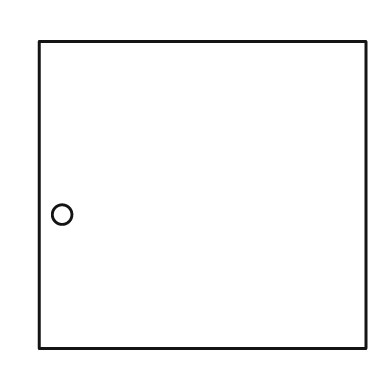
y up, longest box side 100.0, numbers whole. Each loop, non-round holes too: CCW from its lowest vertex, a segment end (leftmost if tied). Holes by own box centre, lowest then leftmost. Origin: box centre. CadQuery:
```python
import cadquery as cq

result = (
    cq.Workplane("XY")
    .moveTo(-50.0, -47.0)
    .lineTo(50.0, -47.0)
    .lineTo(50.0, 47.0)
    .lineTo(-50.0, 47.0)
    .close()
    .moveTo(-43.0, -6.0)
    .circle(3.0)
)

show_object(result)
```